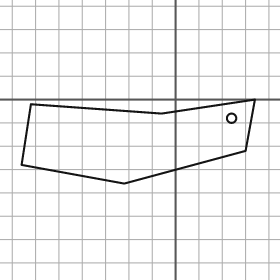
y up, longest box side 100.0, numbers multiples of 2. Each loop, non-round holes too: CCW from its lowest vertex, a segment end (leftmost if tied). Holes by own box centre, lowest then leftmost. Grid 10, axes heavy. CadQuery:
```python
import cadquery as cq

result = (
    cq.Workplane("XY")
    .moveTo(-22.0, -36.0)
    .lineTo(30.0, -22.0)
    .lineTo(34.0, 0.0)
    .lineTo(-6.0, -6.0)
    .lineTo(-62.0, -2.0)
    .lineTo(-66.0, -28.0)
    .close()
    .moveTo(24.0, -8.0)
    .circle(2.0)
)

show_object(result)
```